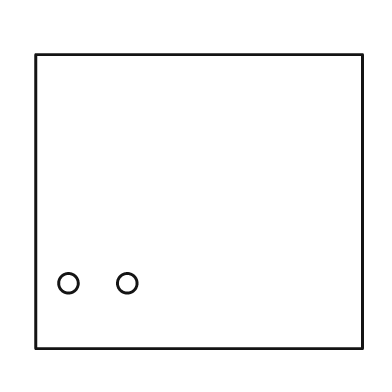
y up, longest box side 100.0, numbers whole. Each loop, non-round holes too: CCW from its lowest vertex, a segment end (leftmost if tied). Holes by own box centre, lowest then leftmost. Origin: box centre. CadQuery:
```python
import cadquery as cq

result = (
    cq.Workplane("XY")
    .moveTo(-50.0, -45.0)
    .lineTo(50.0, -45.0)
    .lineTo(50.0, 45.0)
    .lineTo(-50.0, 45.0)
    .close()
    .moveTo(-40.0, -25.0)
    .circle(3.0)
    .moveTo(-22.0, -25.0)
    .circle(3.0)
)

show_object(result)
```